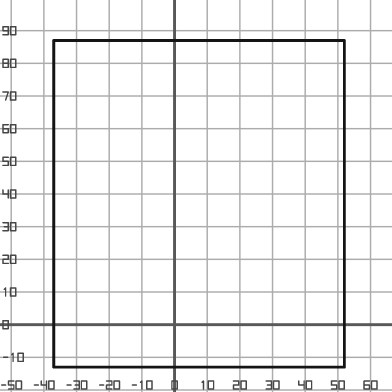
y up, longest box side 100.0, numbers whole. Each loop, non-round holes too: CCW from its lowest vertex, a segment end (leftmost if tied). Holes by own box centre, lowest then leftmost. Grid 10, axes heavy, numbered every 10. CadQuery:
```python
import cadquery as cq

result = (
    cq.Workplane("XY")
    .moveTo(-37.0, -13.0)
    .lineTo(52.0, -13.0)
    .lineTo(52.0, 87.0)
    .lineTo(-37.0, 87.0)
    .close()
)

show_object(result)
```